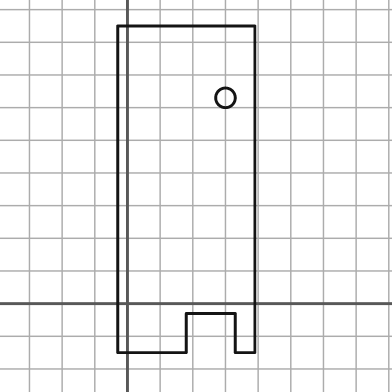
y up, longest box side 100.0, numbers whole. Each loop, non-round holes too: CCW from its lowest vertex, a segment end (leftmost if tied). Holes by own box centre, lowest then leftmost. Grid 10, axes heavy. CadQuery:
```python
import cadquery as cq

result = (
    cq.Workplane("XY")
    .moveTo(-3.0, -15.0)
    .lineTo(18.0, -15.0)
    .lineTo(18.0, -3.0)
    .lineTo(33.0, -3.0)
    .lineTo(33.0, -15.0)
    .lineTo(39.0, -15.0)
    .lineTo(39.0, 85.0)
    .lineTo(-3.0, 85.0)
    .close()
    .moveTo(30.0, 63.0)
    .circle(3.0)
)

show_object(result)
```